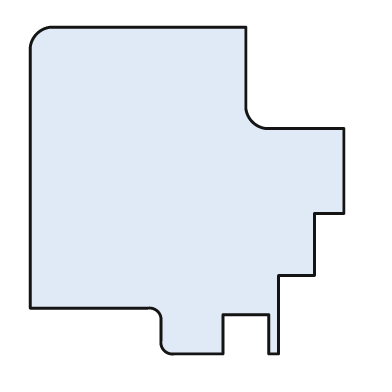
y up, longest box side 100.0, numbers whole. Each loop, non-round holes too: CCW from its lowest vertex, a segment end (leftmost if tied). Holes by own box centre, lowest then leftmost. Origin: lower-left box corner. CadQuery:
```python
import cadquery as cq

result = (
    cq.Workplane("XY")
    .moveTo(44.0, 0.0)
    .lineTo(59.0, 0.0)
    .lineTo(59.0, 12.0)
    .lineTo(73.0, 12.0)
    .lineTo(73.0, 0.0)
    .lineTo(76.0, 0.0)
    .lineTo(76.0, 24.0)
    .lineTo(87.0, 24.0)
    .lineTo(87.0, 43.0)
    .lineTo(96.0, 43.0)
    .lineTo(96.0, 69.0)
    .lineTo(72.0, 69.0)
    .threePointArc((68.0, 71.0), (66.0, 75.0))
    .lineTo(66.0, 100.0)
    .lineTo(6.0, 100.0)
    .threePointArc((2.0, 98.0), (0.0, 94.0))
    .lineTo(0.0, 14.0)
    .lineTo(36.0, 14.0)
    .threePointArc((39.0, 13.0), (40.0, 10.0))
    .lineTo(40.0, 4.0)
    .threePointArc((41.0, 1.0), (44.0, 0.0))
    .close()
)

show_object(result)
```